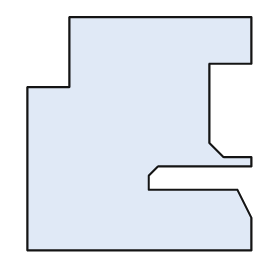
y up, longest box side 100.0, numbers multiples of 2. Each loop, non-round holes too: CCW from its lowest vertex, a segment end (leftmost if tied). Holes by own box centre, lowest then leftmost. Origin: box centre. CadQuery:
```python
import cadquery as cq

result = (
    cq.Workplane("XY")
    .moveTo(-48.0, -50.0)
    .lineTo(48.0, -50.0)
    .lineTo(48.0, -36.0)
    .lineTo(42.0, -24.0)
    .lineTo(4.0, -24.0)
    .lineTo(4.0, -18.0)
    .lineTo(8.0, -14.0)
    .lineTo(48.0, -14.0)
    .lineTo(48.0, -10.0)
    .lineTo(36.0, -10.0)
    .lineTo(30.0, -4.0)
    .lineTo(30.0, 30.0)
    .lineTo(48.0, 30.0)
    .lineTo(48.0, 50.0)
    .lineTo(-30.0, 50.0)
    .lineTo(-30.0, 20.0)
    .lineTo(-48.0, 20.0)
    .close()
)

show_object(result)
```